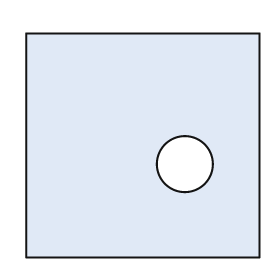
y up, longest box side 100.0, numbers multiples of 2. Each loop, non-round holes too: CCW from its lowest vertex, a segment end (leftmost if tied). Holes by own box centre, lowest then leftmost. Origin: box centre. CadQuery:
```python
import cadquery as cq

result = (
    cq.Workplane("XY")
    .moveTo(-50.0, -48.0)
    .lineTo(50.0, -48.0)
    .lineTo(50.0, 48.0)
    .lineTo(-50.0, 48.0)
    .close()
    .moveTo(18.0, -8.0)
    .circle(12.0)
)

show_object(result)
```